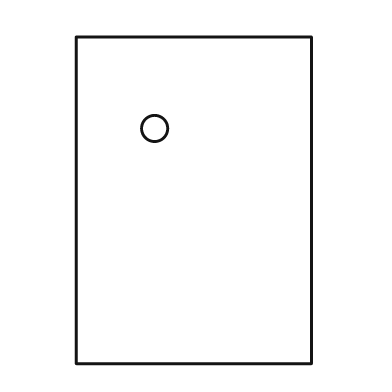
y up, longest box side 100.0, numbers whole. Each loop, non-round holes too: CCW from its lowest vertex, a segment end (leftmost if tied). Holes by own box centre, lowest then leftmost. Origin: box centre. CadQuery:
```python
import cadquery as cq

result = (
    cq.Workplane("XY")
    .moveTo(-36.0, -50.0)
    .lineTo(36.0, -50.0)
    .lineTo(36.0, 50.0)
    .lineTo(-36.0, 50.0)
    .close()
    .moveTo(-12.0, 22.0)
    .circle(4.0)
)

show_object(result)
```